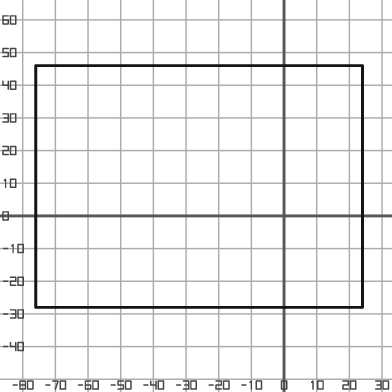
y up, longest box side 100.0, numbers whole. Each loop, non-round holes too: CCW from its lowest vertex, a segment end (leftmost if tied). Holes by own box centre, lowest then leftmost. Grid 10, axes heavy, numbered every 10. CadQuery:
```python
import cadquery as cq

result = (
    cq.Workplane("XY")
    .moveTo(-76.0, -28.0)
    .lineTo(24.0, -28.0)
    .lineTo(24.0, 46.0)
    .lineTo(-76.0, 46.0)
    .close()
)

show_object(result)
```